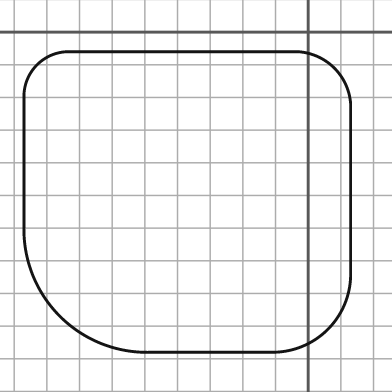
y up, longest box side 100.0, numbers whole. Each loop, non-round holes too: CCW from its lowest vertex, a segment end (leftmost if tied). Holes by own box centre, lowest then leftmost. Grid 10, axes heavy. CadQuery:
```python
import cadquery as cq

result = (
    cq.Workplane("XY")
    .moveTo(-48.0, -98.0)
    .lineTo(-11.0, -98.0)
    .threePointArc((6.0, -91.0), (13.0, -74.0))
    .lineTo(13.0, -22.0)
    .threePointArc((8.0, -11.0), (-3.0, -6.0))
    .lineTo(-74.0, -6.0)
    .threePointArc((-83.0, -10.0), (-87.0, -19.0))
    .lineTo(-87.0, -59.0)
    .threePointArc((-76.0, -87.0), (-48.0, -98.0))
    .close()
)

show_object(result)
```